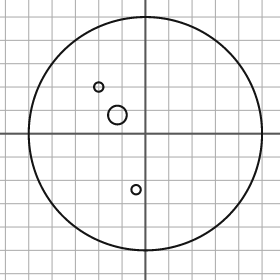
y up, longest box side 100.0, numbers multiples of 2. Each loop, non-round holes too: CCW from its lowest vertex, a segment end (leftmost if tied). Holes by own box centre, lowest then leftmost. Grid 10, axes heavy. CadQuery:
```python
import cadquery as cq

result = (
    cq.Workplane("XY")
    .moveTo(0.0, 0.0)
    .circle(50.0)
    .moveTo(-4.0, -24.0)
    .circle(2.0)
    .moveTo(-12.0, 8.0)
    .circle(4.0)
    .moveTo(-20.0, 20.0)
    .circle(2.0)
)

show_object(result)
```